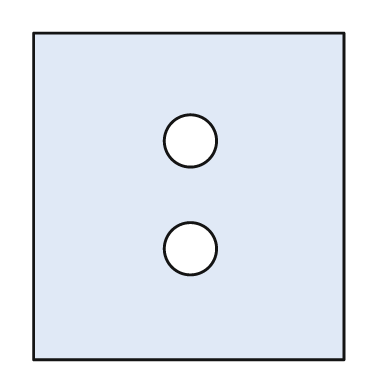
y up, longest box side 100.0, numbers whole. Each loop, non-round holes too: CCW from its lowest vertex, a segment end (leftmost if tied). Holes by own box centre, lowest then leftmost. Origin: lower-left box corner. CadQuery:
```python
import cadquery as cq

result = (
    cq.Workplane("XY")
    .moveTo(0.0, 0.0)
    .lineTo(95.0, 0.0)
    .lineTo(95.0, 100.0)
    .lineTo(0.0, 100.0)
    .close()
    .moveTo(48.0, 34.0)
    .circle(8.0)
    .moveTo(48.0, 67.0)
    .circle(8.0)
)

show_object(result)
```